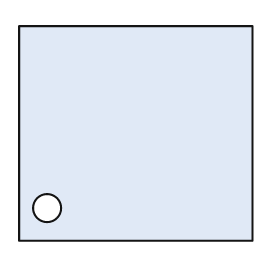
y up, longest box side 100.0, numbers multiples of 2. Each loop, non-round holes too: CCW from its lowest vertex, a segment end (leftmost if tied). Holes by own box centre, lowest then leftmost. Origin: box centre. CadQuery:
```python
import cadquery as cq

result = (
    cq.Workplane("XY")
    .moveTo(-50.0, -46.0)
    .lineTo(50.0, -46.0)
    .lineTo(50.0, 46.0)
    .lineTo(-50.0, 46.0)
    .close()
    .moveTo(-38.0, -32.0)
    .circle(6.0)
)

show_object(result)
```